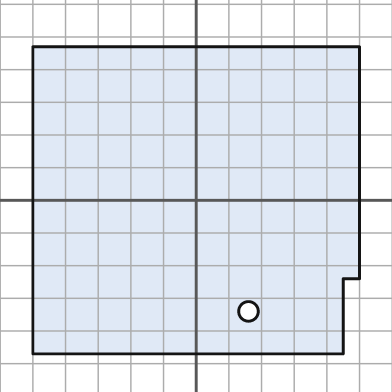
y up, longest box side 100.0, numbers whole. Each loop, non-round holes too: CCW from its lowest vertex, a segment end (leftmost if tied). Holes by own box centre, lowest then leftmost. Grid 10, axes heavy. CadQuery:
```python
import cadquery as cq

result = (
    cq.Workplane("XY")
    .moveTo(-50.0, -47.0)
    .lineTo(45.0, -47.0)
    .lineTo(45.0, -24.0)
    .lineTo(50.0, -24.0)
    .lineTo(50.0, 47.0)
    .lineTo(-50.0, 47.0)
    .close()
    .moveTo(16.0, -34.0)
    .circle(3.0)
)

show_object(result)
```